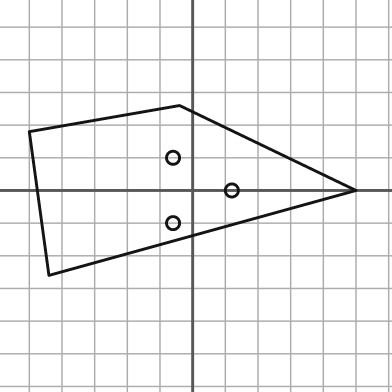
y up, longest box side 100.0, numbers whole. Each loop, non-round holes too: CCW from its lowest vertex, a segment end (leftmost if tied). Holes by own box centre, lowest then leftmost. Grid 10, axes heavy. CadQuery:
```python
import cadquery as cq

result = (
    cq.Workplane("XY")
    .moveTo(-44.0, -26.0)
    .lineTo(50.0, 0.0)
    .lineTo(-4.0, 26.0)
    .lineTo(-50.0, 18.0)
    .close()
    .moveTo(-6.0, -10.0)
    .circle(2.0)
    .moveTo(12.0, 0.0)
    .circle(2.0)
    .moveTo(-6.0, 10.0)
    .circle(2.0)
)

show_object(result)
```